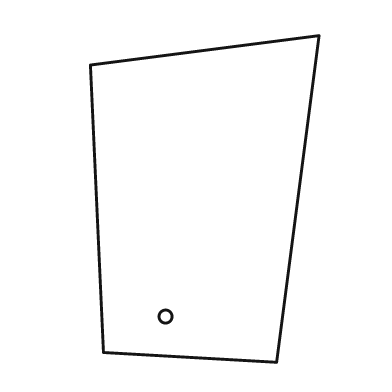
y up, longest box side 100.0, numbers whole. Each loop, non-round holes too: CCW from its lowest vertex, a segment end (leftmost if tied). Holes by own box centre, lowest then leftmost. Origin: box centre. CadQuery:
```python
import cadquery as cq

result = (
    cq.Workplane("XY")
    .moveTo(22.0, -50.0)
    .lineTo(35.0, 50.0)
    .lineTo(-35.0, 41.0)
    .lineTo(-31.0, -47.0)
    .close()
    .moveTo(-12.0, -36.0)
    .circle(2.0)
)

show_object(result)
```